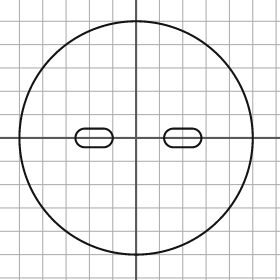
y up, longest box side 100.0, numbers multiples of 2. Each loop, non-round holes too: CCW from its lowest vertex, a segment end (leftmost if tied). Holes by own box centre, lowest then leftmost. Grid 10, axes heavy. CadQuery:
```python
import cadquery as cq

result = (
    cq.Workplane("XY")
    .moveTo(0.0, 0.0)
    .circle(50.0)
    .moveTo(-22.0, -4.0)
    .lineTo(-14.0, -4.0)
    .threePointArc((-10.0, 0.0), (-14.0, 4.0))
    .lineTo(-22.0, 4.0)
    .threePointArc((-26.0, 0.0), (-22.0, -4.0))
    .close()
    .moveTo(16.0, -4.0)
    .lineTo(24.0, -4.0)
    .threePointArc((28.0, 0.0), (24.0, 4.0))
    .lineTo(16.0, 4.0)
    .threePointArc((12.0, 0.0), (16.0, -4.0))
    .close()
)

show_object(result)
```